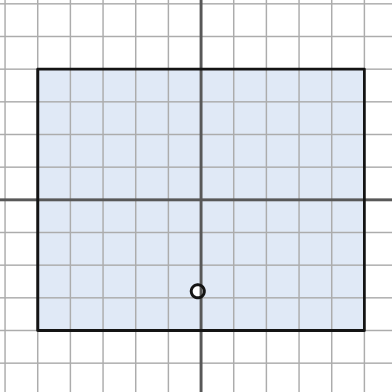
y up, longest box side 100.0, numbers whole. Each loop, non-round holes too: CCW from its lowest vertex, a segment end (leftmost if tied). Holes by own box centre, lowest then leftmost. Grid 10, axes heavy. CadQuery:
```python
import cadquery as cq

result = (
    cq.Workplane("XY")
    .moveTo(-50.0, -40.0)
    .lineTo(50.0, -40.0)
    .lineTo(50.0, 40.0)
    .lineTo(-50.0, 40.0)
    .close()
    .moveTo(-1.0, -28.0)
    .circle(2.0)
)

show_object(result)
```